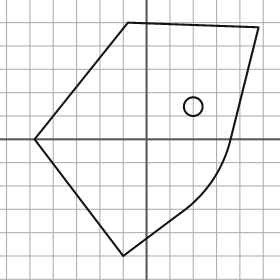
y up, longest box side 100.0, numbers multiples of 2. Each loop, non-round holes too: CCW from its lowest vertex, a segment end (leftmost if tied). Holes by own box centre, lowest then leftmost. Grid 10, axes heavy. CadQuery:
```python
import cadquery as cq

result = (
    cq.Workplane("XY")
    .moveTo(-10.0, -50.0)
    .lineTo(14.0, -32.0)
    .threePointArc((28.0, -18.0), (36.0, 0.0))
    .lineTo(48.0, 48.0)
    .lineTo(-8.0, 50.0)
    .lineTo(-48.0, 0.0)
    .close()
    .moveTo(20.0, 14.0)
    .circle(4.0)
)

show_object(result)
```